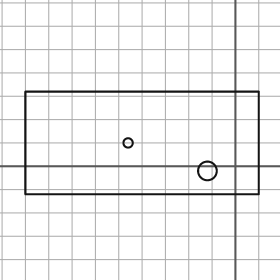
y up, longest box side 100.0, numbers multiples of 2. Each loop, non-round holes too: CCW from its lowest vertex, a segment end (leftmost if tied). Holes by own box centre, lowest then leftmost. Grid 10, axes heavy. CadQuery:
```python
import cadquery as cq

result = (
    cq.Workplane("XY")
    .moveTo(-90.0, -12.0)
    .lineTo(10.0, -12.0)
    .lineTo(10.0, 32.0)
    .lineTo(-90.0, 32.0)
    .close()
    .moveTo(-12.0, -2.0)
    .circle(4.0)
    .moveTo(-46.0, 10.0)
    .circle(2.0)
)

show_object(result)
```